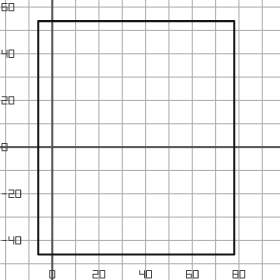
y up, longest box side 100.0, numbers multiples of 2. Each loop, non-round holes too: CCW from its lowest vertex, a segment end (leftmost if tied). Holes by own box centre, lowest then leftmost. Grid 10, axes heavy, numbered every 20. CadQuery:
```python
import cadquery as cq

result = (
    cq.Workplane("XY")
    .moveTo(-6.0, -46.0)
    .lineTo(78.0, -46.0)
    .lineTo(78.0, 54.0)
    .lineTo(-6.0, 54.0)
    .close()
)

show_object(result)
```